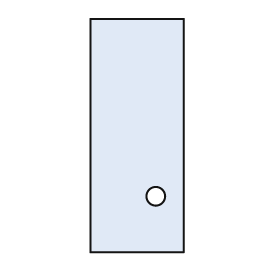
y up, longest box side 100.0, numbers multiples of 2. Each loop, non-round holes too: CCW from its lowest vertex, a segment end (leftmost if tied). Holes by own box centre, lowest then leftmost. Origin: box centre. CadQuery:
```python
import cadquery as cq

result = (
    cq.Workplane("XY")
    .moveTo(-20.0, -50.0)
    .lineTo(20.0, -50.0)
    .lineTo(20.0, 50.0)
    .lineTo(-20.0, 50.0)
    .close()
    .moveTo(8.0, -26.0)
    .circle(4.0)
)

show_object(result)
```